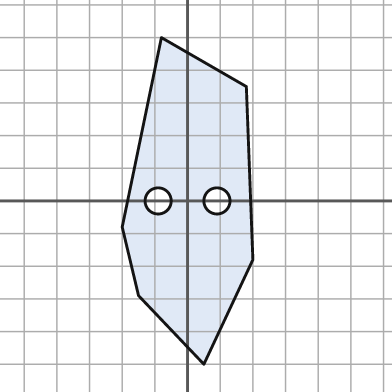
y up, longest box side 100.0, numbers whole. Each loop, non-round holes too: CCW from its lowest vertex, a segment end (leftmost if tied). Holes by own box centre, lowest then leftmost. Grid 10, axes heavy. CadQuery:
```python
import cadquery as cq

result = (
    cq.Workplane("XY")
    .moveTo(5.0, -50.0)
    .lineTo(20.0, -18.0)
    .lineTo(18.0, 35.0)
    .lineTo(-8.0, 50.0)
    .lineTo(-20.0, -8.0)
    .lineTo(-15.0, -29.0)
    .close()
    .moveTo(-9.0, 0.0)
    .circle(4.0)
    .moveTo(9.0, 0.0)
    .circle(4.0)
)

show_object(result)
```